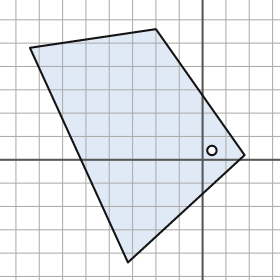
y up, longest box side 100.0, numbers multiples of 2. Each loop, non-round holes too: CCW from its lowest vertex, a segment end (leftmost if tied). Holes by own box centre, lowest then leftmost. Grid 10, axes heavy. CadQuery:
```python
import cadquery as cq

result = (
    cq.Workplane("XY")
    .moveTo(-32.0, -44.0)
    .lineTo(18.0, 2.0)
    .lineTo(-20.0, 56.0)
    .lineTo(-74.0, 48.0)
    .close()
    .moveTo(4.0, 4.0)
    .circle(2.0)
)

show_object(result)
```